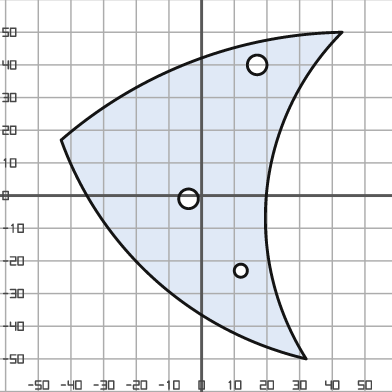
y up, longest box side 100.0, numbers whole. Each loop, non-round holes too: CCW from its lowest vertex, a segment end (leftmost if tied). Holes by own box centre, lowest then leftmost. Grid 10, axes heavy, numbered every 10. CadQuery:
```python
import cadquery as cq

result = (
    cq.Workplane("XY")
    .moveTo(32.0, -50.0)
    .threePointArc((20.0, 2.0), (43.0, 50.0))
    .threePointArc((-3.0, 41.0), (-43.0, 17.0))
    .threePointArc((-14.0, -26.0), (32.0, -50.0))
    .close()
    .moveTo(12.0, -23.0)
    .circle(2.0)
    .moveTo(-4.0, -1.0)
    .circle(3.0)
    .moveTo(17.0, 40.0)
    .circle(3.0)
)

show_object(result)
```